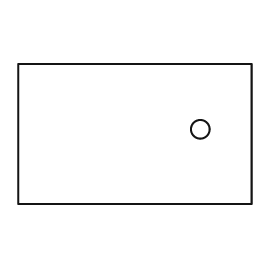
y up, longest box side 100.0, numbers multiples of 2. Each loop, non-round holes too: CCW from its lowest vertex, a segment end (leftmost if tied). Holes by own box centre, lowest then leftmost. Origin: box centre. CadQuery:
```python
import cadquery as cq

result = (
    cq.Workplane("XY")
    .moveTo(-50.0, -30.0)
    .lineTo(50.0, -30.0)
    .lineTo(50.0, 30.0)
    .lineTo(-50.0, 30.0)
    .close()
    .moveTo(28.0, 2.0)
    .circle(4.0)
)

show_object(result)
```